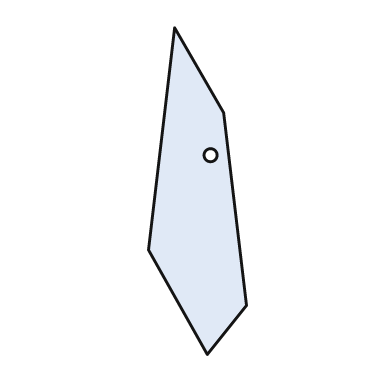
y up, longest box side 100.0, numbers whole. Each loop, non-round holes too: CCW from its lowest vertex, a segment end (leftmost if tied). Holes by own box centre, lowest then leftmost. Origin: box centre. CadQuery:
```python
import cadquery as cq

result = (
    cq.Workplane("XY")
    .moveTo(3.0, -50.0)
    .lineTo(15.0, -35.0)
    .lineTo(8.0, 24.0)
    .lineTo(-7.0, 50.0)
    .lineTo(-15.0, -18.0)
    .close()
    .moveTo(4.0, 11.0)
    .circle(2.0)
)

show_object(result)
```